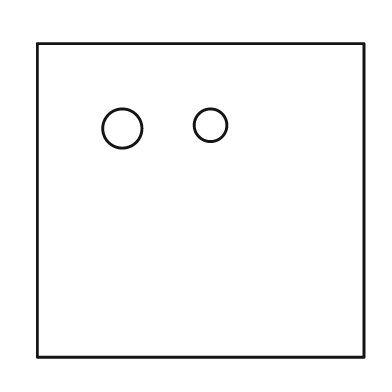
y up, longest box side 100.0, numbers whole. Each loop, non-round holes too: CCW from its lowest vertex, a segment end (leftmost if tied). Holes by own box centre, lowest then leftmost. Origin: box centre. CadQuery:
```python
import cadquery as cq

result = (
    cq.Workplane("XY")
    .moveTo(-50.0, -48.0)
    .lineTo(50.0, -48.0)
    .lineTo(50.0, 48.0)
    .lineTo(-50.0, 48.0)
    .close()
    .moveTo(-24.0, 22.0)
    .circle(6.0)
    .moveTo(3.0, 23.0)
    .circle(5.0)
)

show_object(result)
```